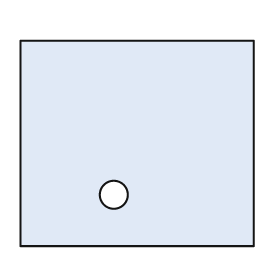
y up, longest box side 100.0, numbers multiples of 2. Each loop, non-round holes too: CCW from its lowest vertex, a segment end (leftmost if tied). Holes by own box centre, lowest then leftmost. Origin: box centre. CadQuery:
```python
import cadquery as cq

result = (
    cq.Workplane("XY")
    .moveTo(-50.0, -44.0)
    .lineTo(50.0, -44.0)
    .lineTo(50.0, 44.0)
    .lineTo(-50.0, 44.0)
    .close()
    .moveTo(-10.0, -22.0)
    .circle(6.0)
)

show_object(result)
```